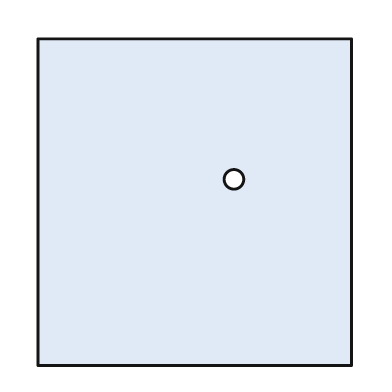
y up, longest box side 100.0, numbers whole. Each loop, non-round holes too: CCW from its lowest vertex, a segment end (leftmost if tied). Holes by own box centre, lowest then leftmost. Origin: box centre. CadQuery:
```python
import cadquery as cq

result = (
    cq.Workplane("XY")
    .moveTo(-48.0, -50.0)
    .lineTo(48.0, -50.0)
    .lineTo(48.0, 50.0)
    .lineTo(-48.0, 50.0)
    .close()
    .moveTo(12.0, 7.0)
    .circle(3.0)
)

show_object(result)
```